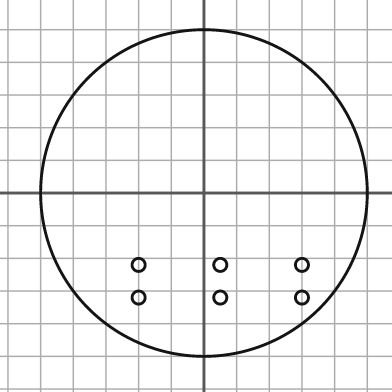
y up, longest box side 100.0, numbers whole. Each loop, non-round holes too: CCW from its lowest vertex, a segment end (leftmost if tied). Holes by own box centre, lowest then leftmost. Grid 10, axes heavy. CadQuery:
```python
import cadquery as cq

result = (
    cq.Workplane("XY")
    .moveTo(0.0, 0.0)
    .circle(50.0)
    .moveTo(-20.0, -32.0)
    .circle(2.0)
    .moveTo(5.0, -32.0)
    .circle(2.0)
    .moveTo(30.0, -32.0)
    .circle(2.0)
    .moveTo(-20.0, -22.0)
    .circle(2.0)
    .moveTo(5.0, -22.0)
    .circle(2.0)
    .moveTo(30.0, -22.0)
    .circle(2.0)
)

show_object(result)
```